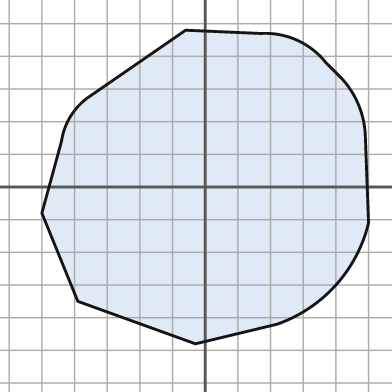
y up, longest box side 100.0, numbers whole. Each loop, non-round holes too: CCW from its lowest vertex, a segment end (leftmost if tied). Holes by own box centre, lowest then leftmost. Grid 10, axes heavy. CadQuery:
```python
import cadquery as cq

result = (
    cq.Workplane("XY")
    .moveTo(-3.0, -48.0)
    .lineTo(22.0, -42.0)
    .threePointArc((40.0, -30.0), (50.0, -11.0))
    .lineTo(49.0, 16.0)
    .threePointArc((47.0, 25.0), (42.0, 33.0))
    .lineTo(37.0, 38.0)
    .threePointArc((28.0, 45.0), (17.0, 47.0))
    .lineTo(-6.0, 48.0)
    .lineTo(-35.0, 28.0)
    .threePointArc((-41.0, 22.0), (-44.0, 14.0))
    .lineTo(-50.0, -8.0)
    .lineTo(-39.0, -35.0)
    .close()
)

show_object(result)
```